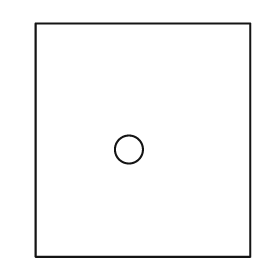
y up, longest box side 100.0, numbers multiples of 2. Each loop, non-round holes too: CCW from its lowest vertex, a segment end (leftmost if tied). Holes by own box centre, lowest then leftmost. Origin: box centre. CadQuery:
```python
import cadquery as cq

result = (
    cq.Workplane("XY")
    .moveTo(-46.0, -50.0)
    .lineTo(46.0, -50.0)
    .lineTo(46.0, 50.0)
    .lineTo(-46.0, 50.0)
    .close()
    .moveTo(-6.0, -4.0)
    .circle(6.0)
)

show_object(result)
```